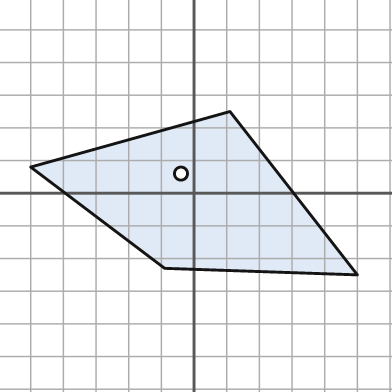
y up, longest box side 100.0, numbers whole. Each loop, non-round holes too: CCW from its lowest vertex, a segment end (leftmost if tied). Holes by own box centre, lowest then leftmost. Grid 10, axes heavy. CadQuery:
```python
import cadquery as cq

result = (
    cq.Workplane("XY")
    .moveTo(50.0, -25.0)
    .lineTo(11.0, 25.0)
    .lineTo(-50.0, 8.0)
    .lineTo(-9.0, -23.0)
    .close()
    .moveTo(-4.0, 6.0)
    .circle(2.0)
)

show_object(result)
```